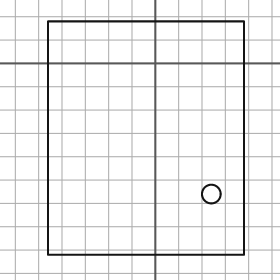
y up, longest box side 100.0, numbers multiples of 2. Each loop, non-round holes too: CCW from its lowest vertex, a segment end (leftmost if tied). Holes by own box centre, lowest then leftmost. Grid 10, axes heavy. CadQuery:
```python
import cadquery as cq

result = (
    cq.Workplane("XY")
    .moveTo(-46.0, -82.0)
    .lineTo(38.0, -82.0)
    .lineTo(38.0, 18.0)
    .lineTo(-46.0, 18.0)
    .close()
    .moveTo(24.0, -56.0)
    .circle(4.0)
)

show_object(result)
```